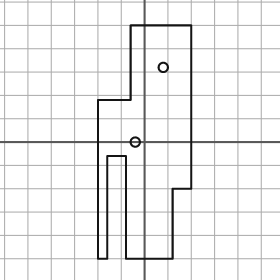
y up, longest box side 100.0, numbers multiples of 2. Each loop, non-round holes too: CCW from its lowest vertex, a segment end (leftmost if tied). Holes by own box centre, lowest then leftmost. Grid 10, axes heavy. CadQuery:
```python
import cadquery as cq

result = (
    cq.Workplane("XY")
    .moveTo(-20.0, -50.0)
    .lineTo(-16.0, -50.0)
    .lineTo(-16.0, -6.0)
    .lineTo(-8.0, -6.0)
    .lineTo(-8.0, -50.0)
    .lineTo(12.0, -50.0)
    .lineTo(12.0, -20.0)
    .lineTo(20.0, -20.0)
    .lineTo(20.0, 50.0)
    .lineTo(-6.0, 50.0)
    .lineTo(-6.0, 18.0)
    .lineTo(-20.0, 18.0)
    .close()
    .moveTo(-4.0, 0.0)
    .circle(2.0)
    .moveTo(8.0, 32.0)
    .circle(2.0)
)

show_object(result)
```